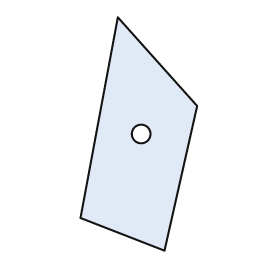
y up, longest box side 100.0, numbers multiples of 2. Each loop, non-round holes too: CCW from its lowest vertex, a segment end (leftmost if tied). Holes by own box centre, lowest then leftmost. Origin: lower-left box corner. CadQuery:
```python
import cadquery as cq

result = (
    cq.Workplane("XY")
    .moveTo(36.0, 0.0)
    .lineTo(50.0, 62.0)
    .lineTo(16.0, 100.0)
    .lineTo(0.0, 14.0)
    .close()
    .moveTo(26.0, 50.0)
    .circle(4.0)
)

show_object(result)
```